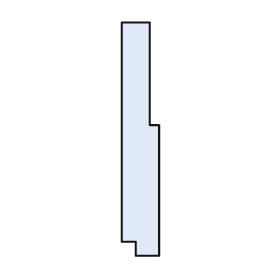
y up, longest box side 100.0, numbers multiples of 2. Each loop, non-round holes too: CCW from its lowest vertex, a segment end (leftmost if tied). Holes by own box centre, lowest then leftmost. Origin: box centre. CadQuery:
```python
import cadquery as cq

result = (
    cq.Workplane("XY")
    .moveTo(-2.0, -50.0)
    .lineTo(8.0, -50.0)
    .lineTo(8.0, 6.0)
    .lineTo(4.0, 6.0)
    .lineTo(4.0, 50.0)
    .lineTo(-8.0, 50.0)
    .lineTo(-8.0, -44.0)
    .lineTo(-2.0, -44.0)
    .close()
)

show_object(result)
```